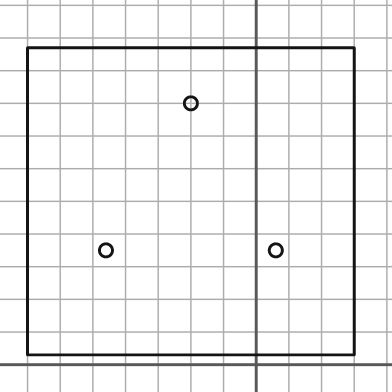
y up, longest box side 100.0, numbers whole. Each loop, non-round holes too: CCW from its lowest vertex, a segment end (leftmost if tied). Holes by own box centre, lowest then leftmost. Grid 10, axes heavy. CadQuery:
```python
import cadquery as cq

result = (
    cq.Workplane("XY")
    .moveTo(-70.0, 3.0)
    .lineTo(30.0, 3.0)
    .lineTo(30.0, 97.0)
    .lineTo(-70.0, 97.0)
    .close()
    .moveTo(-46.0, 35.0)
    .circle(2.0)
    .moveTo(6.0, 35.0)
    .circle(2.0)
    .moveTo(-20.0, 80.0)
    .circle(2.0)
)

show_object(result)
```